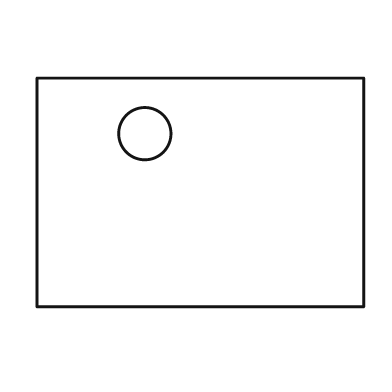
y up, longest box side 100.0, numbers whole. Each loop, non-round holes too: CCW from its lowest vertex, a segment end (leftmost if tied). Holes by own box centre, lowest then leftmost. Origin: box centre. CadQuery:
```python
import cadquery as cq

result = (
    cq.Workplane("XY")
    .moveTo(-50.0, -35.0)
    .lineTo(50.0, -35.0)
    .lineTo(50.0, 35.0)
    .lineTo(-50.0, 35.0)
    .close()
    .moveTo(-17.0, 18.0)
    .circle(8.0)
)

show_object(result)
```